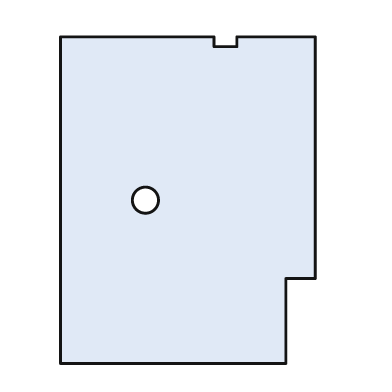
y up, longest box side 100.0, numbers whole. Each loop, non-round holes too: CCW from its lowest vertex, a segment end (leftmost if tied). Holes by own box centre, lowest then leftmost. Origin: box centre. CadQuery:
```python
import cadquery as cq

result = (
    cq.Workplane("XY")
    .moveTo(-39.0, -50.0)
    .lineTo(30.0, -50.0)
    .lineTo(30.0, -24.0)
    .lineTo(39.0, -24.0)
    .lineTo(39.0, 50.0)
    .lineTo(15.0, 50.0)
    .lineTo(15.0, 47.0)
    .lineTo(8.0, 47.0)
    .lineTo(8.0, 50.0)
    .lineTo(-39.0, 50.0)
    .close()
    .moveTo(-13.0, 0.0)
    .circle(4.0)
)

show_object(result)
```